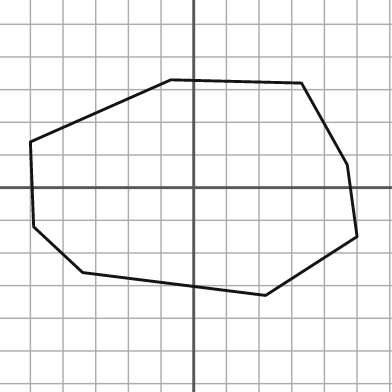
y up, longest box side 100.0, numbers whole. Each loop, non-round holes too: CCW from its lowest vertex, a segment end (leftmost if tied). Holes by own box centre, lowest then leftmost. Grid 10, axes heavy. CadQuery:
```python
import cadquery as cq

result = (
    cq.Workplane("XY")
    .moveTo(22.0, -33.0)
    .lineTo(50.0, -15.0)
    .lineTo(47.0, 7.0)
    .lineTo(33.0, 32.0)
    .lineTo(-7.0, 33.0)
    .lineTo(-50.0, 14.0)
    .lineTo(-49.0, -12.0)
    .lineTo(-34.0, -26.0)
    .close()
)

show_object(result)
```